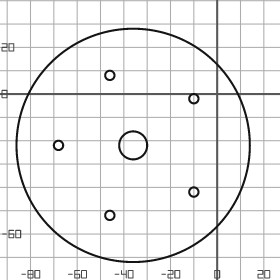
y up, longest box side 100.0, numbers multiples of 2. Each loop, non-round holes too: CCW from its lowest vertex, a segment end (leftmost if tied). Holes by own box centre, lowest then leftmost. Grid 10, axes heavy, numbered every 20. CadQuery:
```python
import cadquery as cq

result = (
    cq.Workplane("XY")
    .moveTo(-36.0, -22.0)
    .circle(50.0)
    .moveTo(-46.0, -52.0)
    .circle(2.0)
    .moveTo(-10.0, -42.0)
    .circle(2.0)
    .moveTo(-68.0, -22.0)
    .circle(2.0)
    .moveTo(-36.0, -22.0)
    .circle(6.0)
    .moveTo(-10.0, -2.0)
    .circle(2.0)
    .moveTo(-46.0, 8.0)
    .circle(2.0)
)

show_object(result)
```